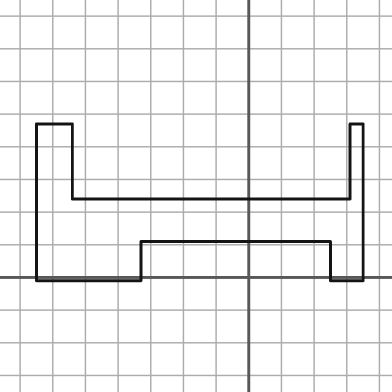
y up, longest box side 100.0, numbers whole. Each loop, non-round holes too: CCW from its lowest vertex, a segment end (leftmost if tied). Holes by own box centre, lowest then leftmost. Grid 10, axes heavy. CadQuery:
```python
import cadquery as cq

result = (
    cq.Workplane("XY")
    .moveTo(-65.0, -1.0)
    .lineTo(-33.0, -1.0)
    .lineTo(-33.0, 11.0)
    .lineTo(25.0, 11.0)
    .lineTo(25.0, -1.0)
    .lineTo(35.0, -1.0)
    .lineTo(35.0, 47.0)
    .lineTo(31.0, 47.0)
    .lineTo(31.0, 24.0)
    .lineTo(-54.0, 24.0)
    .lineTo(-54.0, 47.0)
    .lineTo(-65.0, 47.0)
    .close()
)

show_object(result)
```